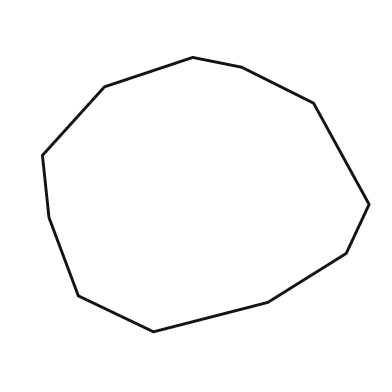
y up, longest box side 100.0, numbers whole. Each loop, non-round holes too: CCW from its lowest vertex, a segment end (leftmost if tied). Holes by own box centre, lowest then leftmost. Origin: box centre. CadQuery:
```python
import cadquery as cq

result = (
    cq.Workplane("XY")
    .moveTo(-16.0, -42.0)
    .lineTo(19.0, -33.0)
    .lineTo(43.0, -18.0)
    .lineTo(50.0, -3.0)
    .lineTo(33.0, 28.0)
    .lineTo(11.0, 39.0)
    .lineTo(-4.0, 42.0)
    .lineTo(-31.0, 33.0)
    .lineTo(-50.0, 12.0)
    .lineTo(-48.0, -7.0)
    .lineTo(-39.0, -31.0)
    .close()
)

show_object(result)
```